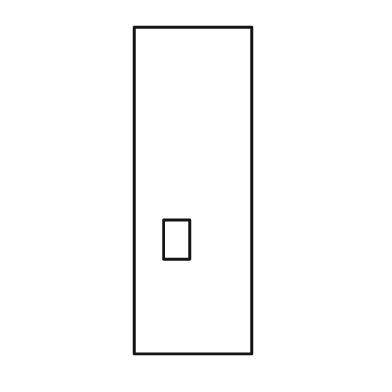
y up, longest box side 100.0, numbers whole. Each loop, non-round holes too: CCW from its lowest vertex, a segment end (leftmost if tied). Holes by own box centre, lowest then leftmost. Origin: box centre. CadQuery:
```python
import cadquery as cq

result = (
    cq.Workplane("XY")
    .moveTo(-18.0, -50.0)
    .lineTo(18.0, -50.0)
    .lineTo(18.0, 50.0)
    .lineTo(-18.0, 50.0)
    .close()
    .moveTo(-9.0, -21.0)
    .lineTo(-1.0, -21.0)
    .lineTo(-1.0, -9.0)
    .lineTo(-9.0, -9.0)
    .close()
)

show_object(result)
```